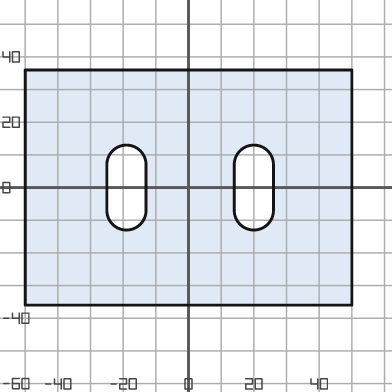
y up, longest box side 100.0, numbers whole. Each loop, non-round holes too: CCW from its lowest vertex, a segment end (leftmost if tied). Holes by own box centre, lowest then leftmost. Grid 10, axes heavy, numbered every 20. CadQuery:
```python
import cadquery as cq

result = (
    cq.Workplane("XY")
    .moveTo(-50.0, -36.0)
    .lineTo(50.0, -36.0)
    .lineTo(50.0, 36.0)
    .lineTo(-50.0, 36.0)
    .close()
    .moveTo(-25.0, -7.0)
    .threePointArc((-19.0, -13.0), (-13.0, -7.0))
    .lineTo(-13.0, 7.0)
    .threePointArc((-19.0, 13.0), (-25.0, 7.0))
    .close()
    .moveTo(14.0, -7.0)
    .threePointArc((20.0, -13.0), (26.0, -7.0))
    .lineTo(26.0, 7.0)
    .threePointArc((20.0, 13.0), (14.0, 7.0))
    .close()
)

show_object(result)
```